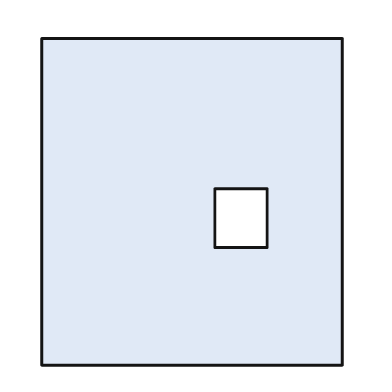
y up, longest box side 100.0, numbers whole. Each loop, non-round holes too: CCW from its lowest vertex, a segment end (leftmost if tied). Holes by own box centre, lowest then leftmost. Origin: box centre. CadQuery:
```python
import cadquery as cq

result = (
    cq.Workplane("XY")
    .moveTo(-46.0, -50.0)
    .lineTo(46.0, -50.0)
    .lineTo(46.0, 50.0)
    .lineTo(-46.0, 50.0)
    .close()
    .moveTo(7.0, -14.0)
    .lineTo(23.0, -14.0)
    .lineTo(23.0, 4.0)
    .lineTo(7.0, 4.0)
    .close()
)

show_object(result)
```